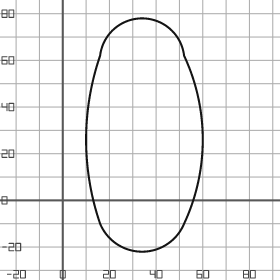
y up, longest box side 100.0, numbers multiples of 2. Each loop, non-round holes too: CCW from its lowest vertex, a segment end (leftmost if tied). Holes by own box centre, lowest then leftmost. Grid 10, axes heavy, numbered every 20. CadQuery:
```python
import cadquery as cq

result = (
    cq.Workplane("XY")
    .moveTo(16.0, -10.0)
    .threePointArc((34.0, -22.0), (52.0, -10.0))
    .threePointArc((60.0, 26.0), (52.0, 62.0))
    .threePointArc((34.0, 78.0), (16.0, 62.0))
    .threePointArc((10.0, 26.0), (16.0, -10.0))
    .close()
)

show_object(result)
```